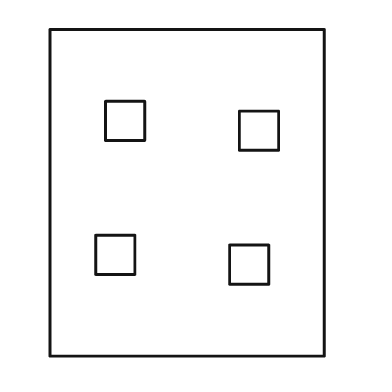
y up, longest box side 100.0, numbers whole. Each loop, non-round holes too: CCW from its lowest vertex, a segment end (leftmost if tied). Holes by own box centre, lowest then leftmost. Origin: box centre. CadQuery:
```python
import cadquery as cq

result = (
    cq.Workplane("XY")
    .moveTo(-42.0, -50.0)
    .lineTo(42.0, -50.0)
    .lineTo(42.0, 50.0)
    .lineTo(-42.0, 50.0)
    .close()
    .moveTo(13.0, -28.0)
    .lineTo(25.0, -28.0)
    .lineTo(25.0, -16.0)
    .lineTo(13.0, -16.0)
    .close()
    .moveTo(-28.0, -25.0)
    .lineTo(-16.0, -25.0)
    .lineTo(-16.0, -13.0)
    .lineTo(-28.0, -13.0)
    .close()
    .moveTo(16.0, 13.0)
    .lineTo(28.0, 13.0)
    .lineTo(28.0, 25.0)
    .lineTo(16.0, 25.0)
    .close()
    .moveTo(-25.0, 16.0)
    .lineTo(-13.0, 16.0)
    .lineTo(-13.0, 28.0)
    .lineTo(-25.0, 28.0)
    .close()
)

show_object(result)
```